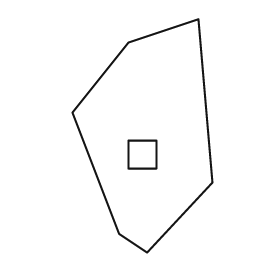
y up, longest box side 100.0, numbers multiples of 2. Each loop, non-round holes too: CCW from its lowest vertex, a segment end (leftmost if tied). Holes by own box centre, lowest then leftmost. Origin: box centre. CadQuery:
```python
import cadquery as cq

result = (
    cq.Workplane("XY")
    .moveTo(2.0, -50.0)
    .lineTo(30.0, -20.0)
    .lineTo(24.0, 50.0)
    .lineTo(-6.0, 40.0)
    .lineTo(-30.0, 10.0)
    .lineTo(-10.0, -42.0)
    .close()
    .moveTo(-6.0, -14.0)
    .lineTo(6.0, -14.0)
    .lineTo(6.0, -2.0)
    .lineTo(-6.0, -2.0)
    .close()
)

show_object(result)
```